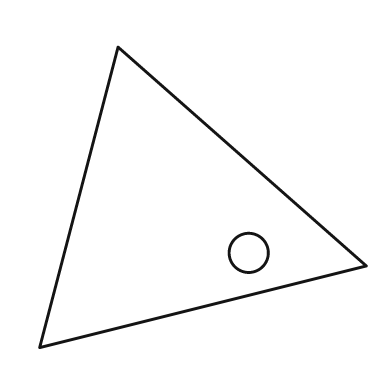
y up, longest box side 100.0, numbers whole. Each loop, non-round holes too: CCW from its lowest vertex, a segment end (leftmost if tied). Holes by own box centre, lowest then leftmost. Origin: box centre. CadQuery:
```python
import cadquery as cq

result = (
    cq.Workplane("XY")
    .moveTo(-50.0, -46.0)
    .lineTo(50.0, -21.0)
    .lineTo(-26.0, 46.0)
    .close()
    .moveTo(14.0, -17.0)
    .circle(6.0)
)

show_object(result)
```